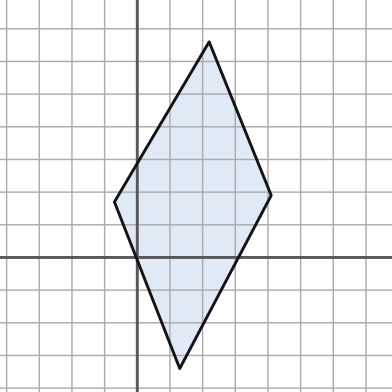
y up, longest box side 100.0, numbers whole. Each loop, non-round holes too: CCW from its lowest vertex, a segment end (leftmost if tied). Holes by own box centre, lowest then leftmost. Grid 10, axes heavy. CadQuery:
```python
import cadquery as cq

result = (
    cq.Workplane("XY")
    .moveTo(13.0, -34.0)
    .lineTo(41.0, 19.0)
    .lineTo(22.0, 66.0)
    .lineTo(-7.0, 17.0)
    .close()
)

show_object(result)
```